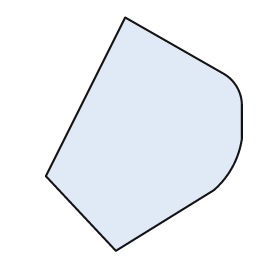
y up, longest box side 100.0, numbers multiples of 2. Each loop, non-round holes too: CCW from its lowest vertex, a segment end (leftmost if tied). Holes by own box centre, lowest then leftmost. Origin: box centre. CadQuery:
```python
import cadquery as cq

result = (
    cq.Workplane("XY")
    .moveTo(-12.0, -50.0)
    .lineTo(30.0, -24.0)
    .threePointArc((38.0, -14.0), (42.0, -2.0))
    .lineTo(42.0, 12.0)
    .threePointArc((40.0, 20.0), (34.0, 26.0))
    .lineTo(-8.0, 50.0)
    .lineTo(-42.0, -18.0)
    .close()
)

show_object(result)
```